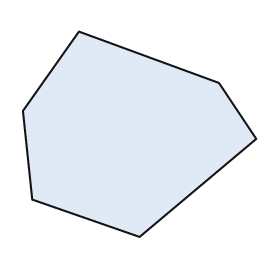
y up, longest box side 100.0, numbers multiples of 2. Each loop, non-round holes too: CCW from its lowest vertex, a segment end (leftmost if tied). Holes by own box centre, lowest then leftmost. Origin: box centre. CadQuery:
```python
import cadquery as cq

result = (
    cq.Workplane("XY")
    .moveTo(0.0, -44.0)
    .lineTo(50.0, -2.0)
    .lineTo(34.0, 22.0)
    .lineTo(-26.0, 44.0)
    .lineTo(-50.0, 10.0)
    .lineTo(-46.0, -28.0)
    .close()
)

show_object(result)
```